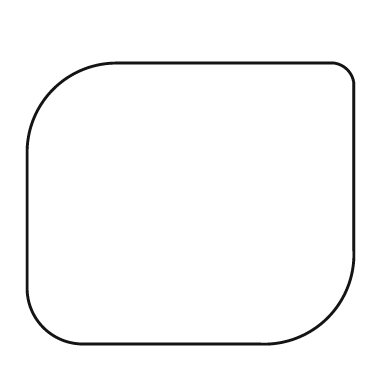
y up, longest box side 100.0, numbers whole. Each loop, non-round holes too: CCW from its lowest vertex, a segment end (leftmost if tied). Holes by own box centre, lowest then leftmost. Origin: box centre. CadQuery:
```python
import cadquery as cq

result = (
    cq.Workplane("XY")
    .moveTo(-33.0, -43.0)
    .lineTo(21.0, -43.0)
    .threePointArc((42.0, -35.0), (50.0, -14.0))
    .lineTo(50.0, 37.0)
    .threePointArc((48.0, 41.0), (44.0, 43.0))
    .lineTo(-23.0, 43.0)
    .threePointArc((-42.0, 35.0), (-50.0, 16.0))
    .lineTo(-50.0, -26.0)
    .threePointArc((-45.0, -38.0), (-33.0, -43.0))
    .close()
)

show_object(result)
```